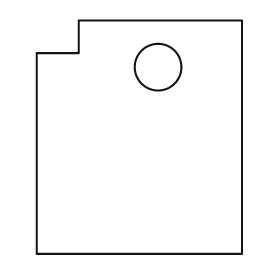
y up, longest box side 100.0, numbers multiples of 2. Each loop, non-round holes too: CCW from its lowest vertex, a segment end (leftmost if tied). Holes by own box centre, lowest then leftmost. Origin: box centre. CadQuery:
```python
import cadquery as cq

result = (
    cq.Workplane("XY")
    .moveTo(-44.0, -50.0)
    .lineTo(44.0, -50.0)
    .lineTo(44.0, 50.0)
    .lineTo(-26.0, 50.0)
    .lineTo(-26.0, 36.0)
    .lineTo(-44.0, 36.0)
    .close()
    .moveTo(8.0, 30.0)
    .circle(10.0)
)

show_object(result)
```